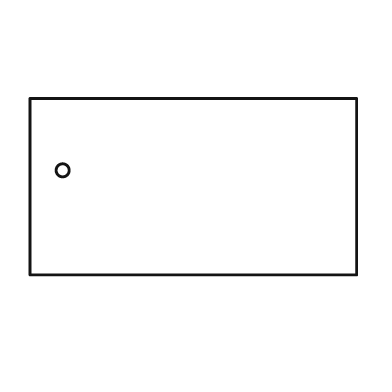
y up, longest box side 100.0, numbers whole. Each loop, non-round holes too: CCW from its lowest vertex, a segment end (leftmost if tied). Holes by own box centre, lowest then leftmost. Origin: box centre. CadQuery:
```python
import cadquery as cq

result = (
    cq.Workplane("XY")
    .moveTo(-50.0, -27.0)
    .lineTo(50.0, -27.0)
    .lineTo(50.0, 27.0)
    .lineTo(-50.0, 27.0)
    .close()
    .moveTo(-40.0, 5.0)
    .circle(2.0)
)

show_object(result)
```